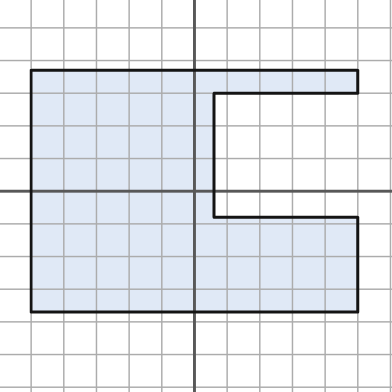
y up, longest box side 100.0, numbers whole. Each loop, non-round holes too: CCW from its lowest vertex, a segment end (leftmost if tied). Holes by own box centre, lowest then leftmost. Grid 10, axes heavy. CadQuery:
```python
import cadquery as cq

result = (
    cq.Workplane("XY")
    .moveTo(-50.0, -37.0)
    .lineTo(50.0, -37.0)
    .lineTo(50.0, -8.0)
    .lineTo(6.0, -8.0)
    .lineTo(6.0, 30.0)
    .lineTo(50.0, 30.0)
    .lineTo(50.0, 37.0)
    .lineTo(-50.0, 37.0)
    .close()
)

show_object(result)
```